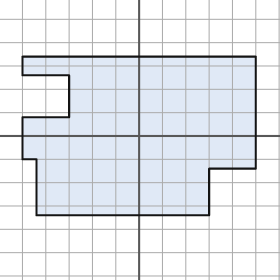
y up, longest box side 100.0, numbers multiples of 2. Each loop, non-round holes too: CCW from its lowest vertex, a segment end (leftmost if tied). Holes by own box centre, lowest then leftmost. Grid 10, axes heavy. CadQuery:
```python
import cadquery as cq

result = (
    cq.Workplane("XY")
    .moveTo(-44.0, -34.0)
    .lineTo(30.0, -34.0)
    .lineTo(30.0, -14.0)
    .lineTo(50.0, -14.0)
    .lineTo(50.0, 34.0)
    .lineTo(-50.0, 34.0)
    .lineTo(-50.0, 26.0)
    .lineTo(-30.0, 26.0)
    .lineTo(-30.0, 8.0)
    .lineTo(-50.0, 8.0)
    .lineTo(-50.0, -10.0)
    .lineTo(-44.0, -10.0)
    .close()
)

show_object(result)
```